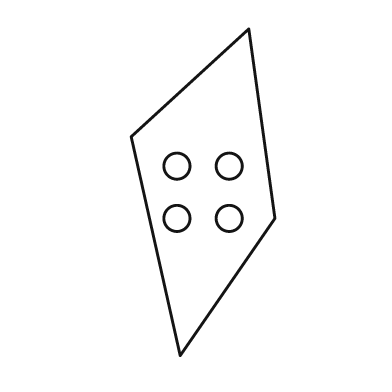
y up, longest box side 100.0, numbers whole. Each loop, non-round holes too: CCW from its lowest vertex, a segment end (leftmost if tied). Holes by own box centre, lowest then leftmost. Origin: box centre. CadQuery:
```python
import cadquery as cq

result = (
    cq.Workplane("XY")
    .moveTo(-7.0, -50.0)
    .lineTo(22.0, -8.0)
    .lineTo(14.0, 50.0)
    .lineTo(-22.0, 17.0)
    .close()
    .moveTo(-8.0, -8.0)
    .circle(4.0)
    .moveTo(8.0, -8.0)
    .circle(4.0)
    .moveTo(-8.0, 8.0)
    .circle(4.0)
    .moveTo(8.0, 8.0)
    .circle(4.0)
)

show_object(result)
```